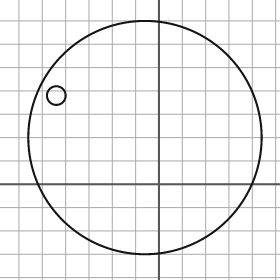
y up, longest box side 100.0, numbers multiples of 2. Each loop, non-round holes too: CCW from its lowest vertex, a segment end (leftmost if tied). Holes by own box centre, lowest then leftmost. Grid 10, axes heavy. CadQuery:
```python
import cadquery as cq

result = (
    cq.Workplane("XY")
    .moveTo(-6.0, 20.0)
    .circle(50.0)
    .moveTo(-44.0, 38.0)
    .circle(4.0)
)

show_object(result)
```